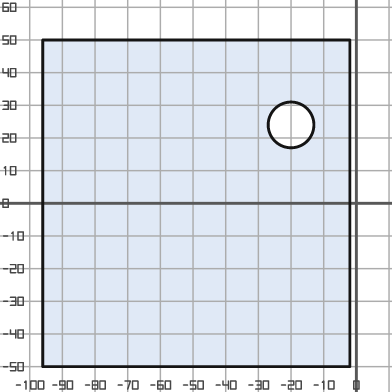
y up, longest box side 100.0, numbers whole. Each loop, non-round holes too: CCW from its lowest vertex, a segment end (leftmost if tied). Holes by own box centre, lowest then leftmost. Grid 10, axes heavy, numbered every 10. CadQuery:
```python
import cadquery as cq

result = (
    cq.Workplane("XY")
    .moveTo(-96.0, -50.0)
    .lineTo(-2.0, -50.0)
    .lineTo(-2.0, 50.0)
    .lineTo(-96.0, 50.0)
    .close()
    .moveTo(-20.0, 24.0)
    .circle(7.0)
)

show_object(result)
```